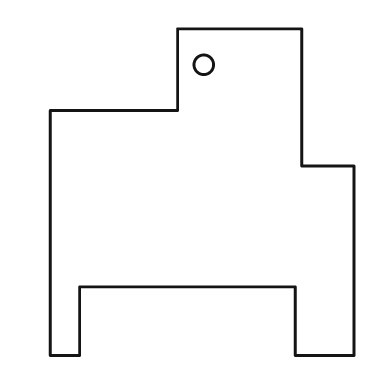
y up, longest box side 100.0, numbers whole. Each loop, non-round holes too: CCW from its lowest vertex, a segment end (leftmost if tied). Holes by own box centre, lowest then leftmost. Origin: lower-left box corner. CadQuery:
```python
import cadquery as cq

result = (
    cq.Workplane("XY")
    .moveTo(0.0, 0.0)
    .lineTo(9.0, 0.0)
    .lineTo(9.0, 21.0)
    .lineTo(75.0, 21.0)
    .lineTo(75.0, 0.0)
    .lineTo(93.0, 0.0)
    .lineTo(93.0, 58.0)
    .lineTo(77.0, 58.0)
    .lineTo(77.0, 100.0)
    .lineTo(39.0, 100.0)
    .lineTo(39.0, 75.0)
    .lineTo(0.0, 75.0)
    .close()
    .moveTo(47.0, 89.0)
    .circle(3.0)
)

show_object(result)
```